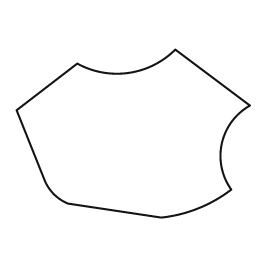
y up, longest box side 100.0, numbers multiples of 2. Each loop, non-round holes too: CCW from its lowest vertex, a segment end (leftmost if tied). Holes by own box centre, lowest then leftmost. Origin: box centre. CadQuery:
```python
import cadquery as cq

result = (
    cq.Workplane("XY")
    .moveTo(12.0, -36.0)
    .threePointArc((28.0, -32.0), (42.0, -24.0))
    .threePointArc((38.0, -4.0), (50.0, 12.0))
    .lineTo(18.0, 36.0)
    .threePointArc((-2.0, 26.0), (-24.0, 30.0))
    .lineTo(-50.0, 10.0)
    .lineTo(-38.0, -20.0)
    .threePointArc((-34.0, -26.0), (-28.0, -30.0))
    .close()
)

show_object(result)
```